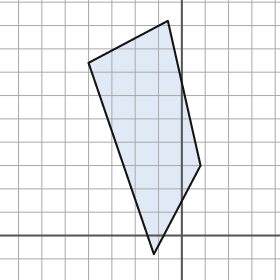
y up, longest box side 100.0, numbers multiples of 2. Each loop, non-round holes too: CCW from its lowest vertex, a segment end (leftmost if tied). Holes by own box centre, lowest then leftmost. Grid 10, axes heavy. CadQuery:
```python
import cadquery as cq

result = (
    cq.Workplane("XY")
    .moveTo(-12.0, -8.0)
    .lineTo(8.0, 30.0)
    .lineTo(-6.0, 92.0)
    .lineTo(-40.0, 74.0)
    .close()
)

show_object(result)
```